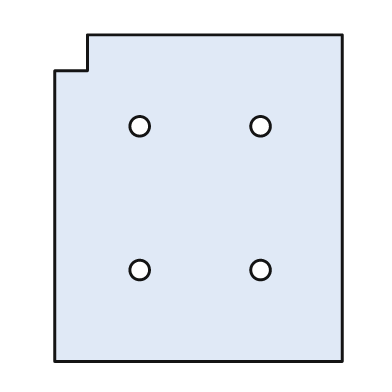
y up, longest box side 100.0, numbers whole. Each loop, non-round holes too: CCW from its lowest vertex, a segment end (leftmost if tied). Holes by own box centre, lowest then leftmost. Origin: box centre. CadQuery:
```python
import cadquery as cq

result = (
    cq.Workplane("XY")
    .moveTo(-44.0, -50.0)
    .lineTo(44.0, -50.0)
    .lineTo(44.0, 50.0)
    .lineTo(-34.0, 50.0)
    .lineTo(-34.0, 39.0)
    .lineTo(-44.0, 39.0)
    .close()
    .moveTo(-18.0, -22.0)
    .circle(3.0)
    .moveTo(19.0, -22.0)
    .circle(3.0)
    .moveTo(-18.0, 22.0)
    .circle(3.0)
    .moveTo(19.0, 22.0)
    .circle(3.0)
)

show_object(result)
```